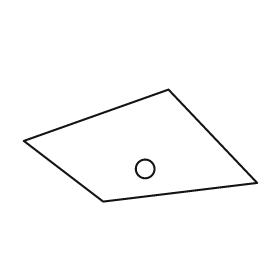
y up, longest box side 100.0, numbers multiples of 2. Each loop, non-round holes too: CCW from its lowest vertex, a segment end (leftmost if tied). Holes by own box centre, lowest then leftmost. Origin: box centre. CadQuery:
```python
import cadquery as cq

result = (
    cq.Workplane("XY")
    .moveTo(-16.0, -24.0)
    .lineTo(50.0, -16.0)
    .lineTo(12.0, 24.0)
    .lineTo(-50.0, 2.0)
    .close()
    .moveTo(2.0, -10.0)
    .circle(4.0)
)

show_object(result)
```